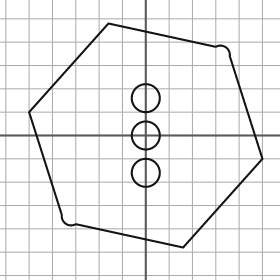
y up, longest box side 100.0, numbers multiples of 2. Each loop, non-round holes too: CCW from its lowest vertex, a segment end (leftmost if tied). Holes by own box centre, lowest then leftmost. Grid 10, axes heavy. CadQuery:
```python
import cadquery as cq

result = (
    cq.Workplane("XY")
    .moveTo(16.0, -48.0)
    .lineTo(50.0, -10.0)
    .lineTo(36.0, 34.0)
    .threePointArc((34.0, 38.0), (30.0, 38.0))
    .lineTo(-16.0, 48.0)
    .lineTo(-50.0, 10.0)
    .lineTo(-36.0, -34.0)
    .threePointArc((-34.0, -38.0), (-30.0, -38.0))
    .close()
    .moveTo(0.0, -16.0)
    .circle(6.0)
    .moveTo(0.0, 0.0)
    .circle(6.0)
    .moveTo(0.0, 16.0)
    .circle(6.0)
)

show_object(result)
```